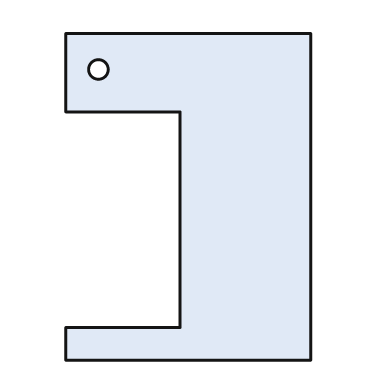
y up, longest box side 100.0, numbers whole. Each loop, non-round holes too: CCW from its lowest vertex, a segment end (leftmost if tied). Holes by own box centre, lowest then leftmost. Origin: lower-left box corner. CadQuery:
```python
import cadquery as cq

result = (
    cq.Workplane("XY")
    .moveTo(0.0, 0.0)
    .lineTo(75.0, 0.0)
    .lineTo(75.0, 100.0)
    .lineTo(0.0, 100.0)
    .lineTo(0.0, 76.0)
    .lineTo(35.0, 76.0)
    .lineTo(35.0, 10.0)
    .lineTo(0.0, 10.0)
    .close()
    .moveTo(10.0, 89.0)
    .circle(3.0)
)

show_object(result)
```